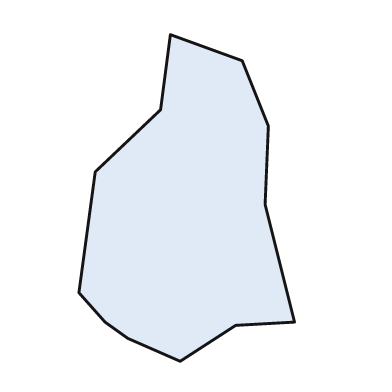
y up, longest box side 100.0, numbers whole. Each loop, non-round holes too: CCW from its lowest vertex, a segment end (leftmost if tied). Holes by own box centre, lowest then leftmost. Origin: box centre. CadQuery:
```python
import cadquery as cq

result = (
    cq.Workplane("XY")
    .moveTo(-2.0, -50.0)
    .lineTo(15.0, -39.0)
    .lineTo(33.0, -38.0)
    .lineTo(24.0, -2.0)
    .lineTo(25.0, 22.0)
    .lineTo(17.0, 42.0)
    .lineTo(-5.0, 50.0)
    .lineTo(-8.0, 27.0)
    .lineTo(-28.0, 8.0)
    .lineTo(-33.0, -29.0)
    .lineTo(-25.0, -38.0)
    .lineTo(-18.0, -43.0)
    .close()
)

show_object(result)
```